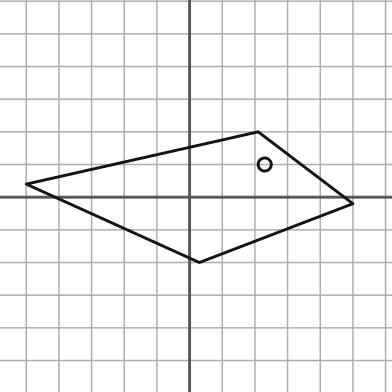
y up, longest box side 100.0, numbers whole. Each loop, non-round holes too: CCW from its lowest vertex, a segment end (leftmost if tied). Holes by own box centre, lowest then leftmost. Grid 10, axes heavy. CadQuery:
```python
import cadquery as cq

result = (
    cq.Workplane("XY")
    .moveTo(3.0, -20.0)
    .lineTo(50.0, -2.0)
    .lineTo(21.0, 20.0)
    .lineTo(-50.0, 4.0)
    .close()
    .moveTo(23.0, 10.0)
    .circle(2.0)
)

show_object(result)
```